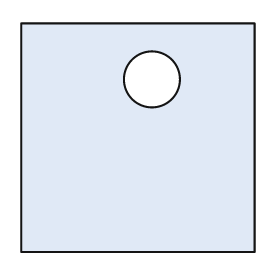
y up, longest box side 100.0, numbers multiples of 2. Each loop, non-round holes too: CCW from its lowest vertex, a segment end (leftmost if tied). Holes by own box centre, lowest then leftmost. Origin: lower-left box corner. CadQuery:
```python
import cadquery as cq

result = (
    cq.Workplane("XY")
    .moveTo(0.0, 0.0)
    .lineTo(100.0, 0.0)
    .lineTo(100.0, 98.0)
    .lineTo(0.0, 98.0)
    .close()
    .moveTo(56.0, 74.0)
    .circle(12.0)
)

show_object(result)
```